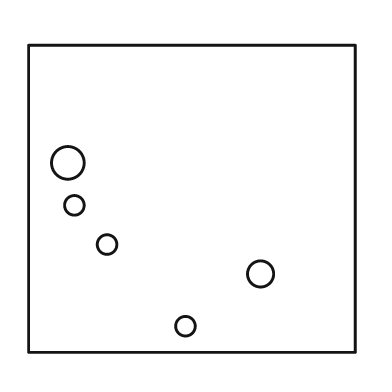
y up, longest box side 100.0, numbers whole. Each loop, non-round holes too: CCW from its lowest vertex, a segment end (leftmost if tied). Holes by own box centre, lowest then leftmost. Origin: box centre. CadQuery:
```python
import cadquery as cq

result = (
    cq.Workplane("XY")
    .moveTo(-50.0, -47.0)
    .lineTo(50.0, -47.0)
    .lineTo(50.0, 47.0)
    .lineTo(-50.0, 47.0)
    .close()
    .moveTo(-2.0, -39.0)
    .circle(3.0)
    .moveTo(21.0, -23.0)
    .circle(4.0)
    .moveTo(-26.0, -14.0)
    .circle(3.0)
    .moveTo(-36.0, -2.0)
    .circle(3.0)
    .moveTo(-38.0, 11.0)
    .circle(5.0)
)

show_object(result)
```